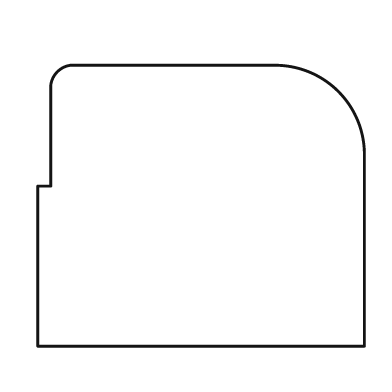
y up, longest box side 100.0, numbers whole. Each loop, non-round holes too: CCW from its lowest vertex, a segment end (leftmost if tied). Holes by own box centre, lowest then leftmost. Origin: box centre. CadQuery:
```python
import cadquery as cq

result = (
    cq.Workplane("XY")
    .moveTo(-50.0, -43.0)
    .lineTo(50.0, -43.0)
    .lineTo(50.0, 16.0)
    .threePointArc((42.0, 35.0), (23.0, 43.0))
    .lineTo(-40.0, 43.0)
    .threePointArc((-44.0, 41.0), (-46.0, 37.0))
    .lineTo(-46.0, 6.0)
    .lineTo(-50.0, 6.0)
    .close()
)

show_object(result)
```